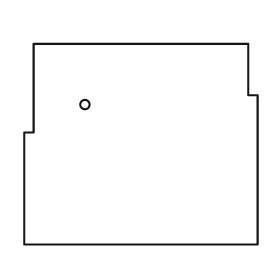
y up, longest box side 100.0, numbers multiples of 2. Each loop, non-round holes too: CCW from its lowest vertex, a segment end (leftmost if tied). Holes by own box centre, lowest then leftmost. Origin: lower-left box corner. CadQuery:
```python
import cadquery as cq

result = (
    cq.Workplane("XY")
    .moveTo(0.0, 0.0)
    .lineTo(100.0, 0.0)
    .lineTo(100.0, 64.0)
    .lineTo(96.0, 64.0)
    .lineTo(96.0, 86.0)
    .lineTo(4.0, 86.0)
    .lineTo(4.0, 48.0)
    .lineTo(0.0, 48.0)
    .close()
    .moveTo(26.0, 60.0)
    .circle(2.0)
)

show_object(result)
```